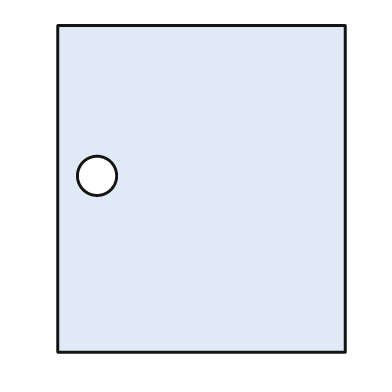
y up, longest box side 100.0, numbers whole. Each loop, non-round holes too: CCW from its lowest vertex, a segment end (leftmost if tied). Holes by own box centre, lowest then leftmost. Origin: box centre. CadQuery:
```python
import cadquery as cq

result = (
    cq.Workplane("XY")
    .moveTo(-44.0, -50.0)
    .lineTo(44.0, -50.0)
    .lineTo(44.0, 50.0)
    .lineTo(-44.0, 50.0)
    .close()
    .moveTo(-32.0, 4.0)
    .circle(6.0)
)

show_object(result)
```